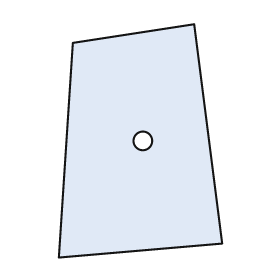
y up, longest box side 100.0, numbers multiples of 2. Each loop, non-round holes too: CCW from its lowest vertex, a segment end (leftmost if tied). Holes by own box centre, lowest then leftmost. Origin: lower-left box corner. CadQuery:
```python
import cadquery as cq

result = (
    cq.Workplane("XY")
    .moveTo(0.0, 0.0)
    .lineTo(70.0, 6.0)
    .lineTo(58.0, 100.0)
    .lineTo(6.0, 92.0)
    .close()
    .moveTo(36.0, 50.0)
    .circle(4.0)
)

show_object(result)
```